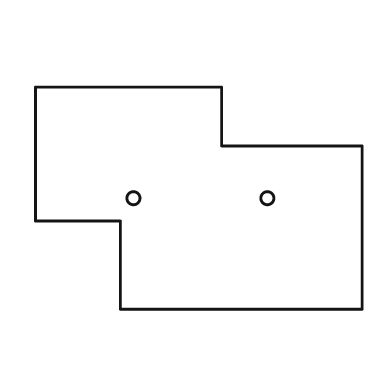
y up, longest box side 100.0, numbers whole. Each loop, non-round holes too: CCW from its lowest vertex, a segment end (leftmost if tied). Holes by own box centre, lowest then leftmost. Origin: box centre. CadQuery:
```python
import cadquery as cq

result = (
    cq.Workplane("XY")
    .moveTo(-24.0, -34.0)
    .lineTo(50.0, -34.0)
    .lineTo(50.0, 16.0)
    .lineTo(7.0, 16.0)
    .lineTo(7.0, 34.0)
    .lineTo(-50.0, 34.0)
    .lineTo(-50.0, -7.0)
    .lineTo(-24.0, -7.0)
    .close()
    .moveTo(-20.0, 0.0)
    .circle(2.0)
    .moveTo(21.0, 0.0)
    .circle(2.0)
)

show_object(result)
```